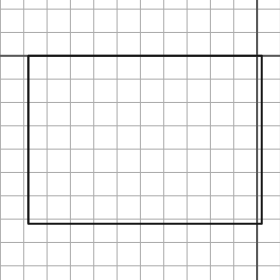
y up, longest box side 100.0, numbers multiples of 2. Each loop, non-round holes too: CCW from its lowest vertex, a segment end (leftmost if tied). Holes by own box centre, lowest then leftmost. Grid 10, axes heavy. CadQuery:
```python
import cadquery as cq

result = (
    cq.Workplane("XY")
    .moveTo(-98.0, -72.0)
    .lineTo(2.0, -72.0)
    .lineTo(2.0, 0.0)
    .lineTo(-98.0, 0.0)
    .close()
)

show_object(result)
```